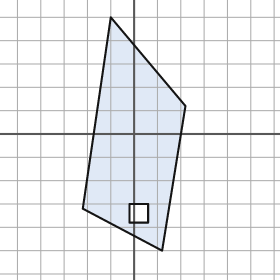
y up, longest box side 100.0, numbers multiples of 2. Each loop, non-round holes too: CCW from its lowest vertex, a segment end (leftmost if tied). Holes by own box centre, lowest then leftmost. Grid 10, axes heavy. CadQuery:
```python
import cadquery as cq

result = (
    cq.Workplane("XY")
    .moveTo(12.0, -50.0)
    .lineTo(22.0, 12.0)
    .lineTo(-10.0, 50.0)
    .lineTo(-22.0, -32.0)
    .close()
    .moveTo(-2.0, -38.0)
    .lineTo(6.0, -38.0)
    .lineTo(6.0, -30.0)
    .lineTo(-2.0, -30.0)
    .close()
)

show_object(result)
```